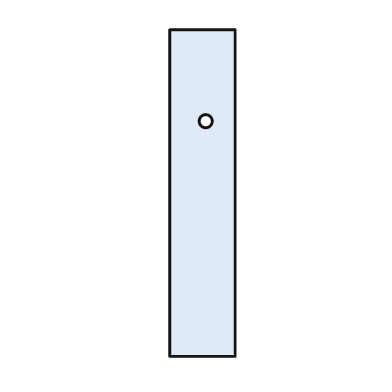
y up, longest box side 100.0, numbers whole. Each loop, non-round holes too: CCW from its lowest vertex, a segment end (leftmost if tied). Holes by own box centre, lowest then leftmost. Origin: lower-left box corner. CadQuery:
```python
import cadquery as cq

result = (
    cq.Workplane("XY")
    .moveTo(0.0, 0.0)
    .lineTo(20.0, 0.0)
    .lineTo(20.0, 100.0)
    .lineTo(0.0, 100.0)
    .close()
    .moveTo(11.0, 72.0)
    .circle(2.0)
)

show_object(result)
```